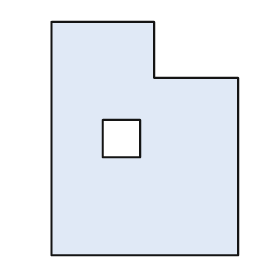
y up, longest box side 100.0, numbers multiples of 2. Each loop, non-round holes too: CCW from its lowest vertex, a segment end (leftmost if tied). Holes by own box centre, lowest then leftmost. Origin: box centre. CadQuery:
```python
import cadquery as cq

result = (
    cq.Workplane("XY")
    .moveTo(-40.0, -50.0)
    .lineTo(40.0, -50.0)
    .lineTo(40.0, 26.0)
    .lineTo(4.0, 26.0)
    .lineTo(4.0, 50.0)
    .lineTo(-40.0, 50.0)
    .close()
    .moveTo(-18.0, -8.0)
    .lineTo(-2.0, -8.0)
    .lineTo(-2.0, 8.0)
    .lineTo(-18.0, 8.0)
    .close()
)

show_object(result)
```